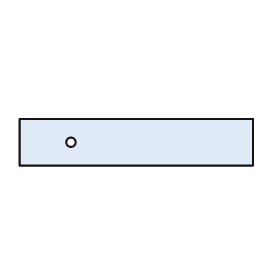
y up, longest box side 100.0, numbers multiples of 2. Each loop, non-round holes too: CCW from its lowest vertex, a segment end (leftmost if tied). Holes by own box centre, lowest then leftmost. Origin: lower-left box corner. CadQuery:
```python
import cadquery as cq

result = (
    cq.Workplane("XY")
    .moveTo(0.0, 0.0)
    .lineTo(100.0, 0.0)
    .lineTo(100.0, 20.0)
    .lineTo(0.0, 20.0)
    .close()
    .moveTo(22.0, 10.0)
    .circle(2.0)
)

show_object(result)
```